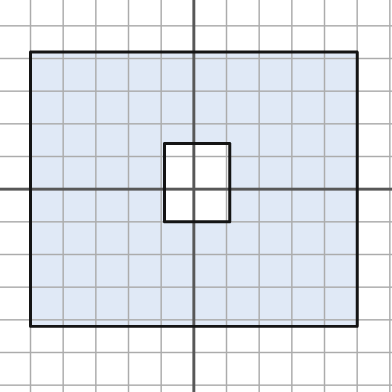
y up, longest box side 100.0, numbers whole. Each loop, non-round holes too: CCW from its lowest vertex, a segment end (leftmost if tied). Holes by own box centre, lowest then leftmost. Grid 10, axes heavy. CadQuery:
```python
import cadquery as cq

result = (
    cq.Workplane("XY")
    .moveTo(-50.0, -42.0)
    .lineTo(50.0, -42.0)
    .lineTo(50.0, 42.0)
    .lineTo(-50.0, 42.0)
    .close()
    .moveTo(-9.0, -10.0)
    .lineTo(11.0, -10.0)
    .lineTo(11.0, 14.0)
    .lineTo(-9.0, 14.0)
    .close()
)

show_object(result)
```